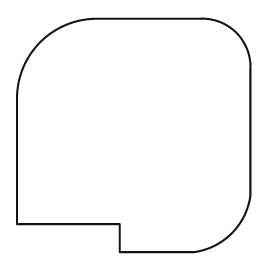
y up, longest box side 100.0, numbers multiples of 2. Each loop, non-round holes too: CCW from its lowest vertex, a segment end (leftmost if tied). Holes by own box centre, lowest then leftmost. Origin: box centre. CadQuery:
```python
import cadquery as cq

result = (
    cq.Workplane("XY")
    .moveTo(-6.0, -50.0)
    .lineTo(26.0, -50.0)
    .threePointArc((42.0, -42.0), (50.0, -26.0))
    .lineTo(50.0, 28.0)
    .threePointArc((44.0, 44.0), (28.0, 50.0))
    .lineTo(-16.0, 50.0)
    .threePointArc((-40.0, 40.0), (-50.0, 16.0))
    .lineTo(-50.0, -38.0)
    .lineTo(-6.0, -38.0)
    .close()
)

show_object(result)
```